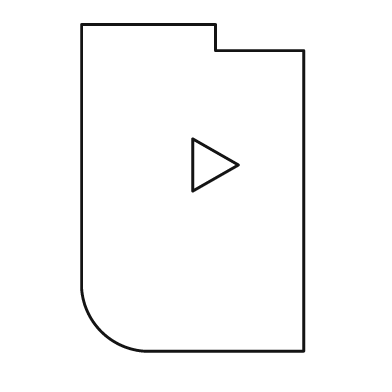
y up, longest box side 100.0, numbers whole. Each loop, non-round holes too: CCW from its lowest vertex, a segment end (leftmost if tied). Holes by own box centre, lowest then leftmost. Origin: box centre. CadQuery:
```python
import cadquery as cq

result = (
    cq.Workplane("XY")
    .moveTo(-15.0, -50.0)
    .lineTo(34.0, -50.0)
    .lineTo(34.0, 42.0)
    .lineTo(7.0, 42.0)
    .lineTo(7.0, 50.0)
    .lineTo(-34.0, 50.0)
    .lineTo(-34.0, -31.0)
    .threePointArc((-28.0, -44.0), (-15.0, -50.0))
    .close()
    .moveTo(0.0, -1.0)
    .lineTo(14.0, 7.0)
    .lineTo(0.0, 15.0)
    .close()
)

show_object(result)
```